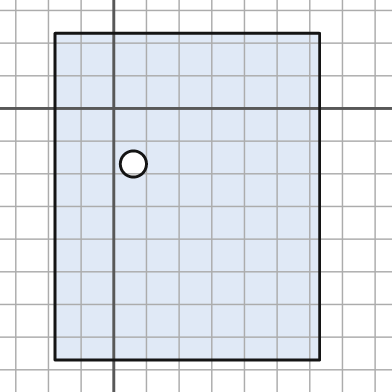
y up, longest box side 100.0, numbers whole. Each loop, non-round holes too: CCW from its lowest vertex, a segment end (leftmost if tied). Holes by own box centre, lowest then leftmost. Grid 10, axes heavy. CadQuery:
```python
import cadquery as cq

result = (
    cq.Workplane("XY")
    .moveTo(-18.0, -77.0)
    .lineTo(63.0, -77.0)
    .lineTo(63.0, 23.0)
    .lineTo(-18.0, 23.0)
    .close()
    .moveTo(6.0, -17.0)
    .circle(4.0)
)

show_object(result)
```